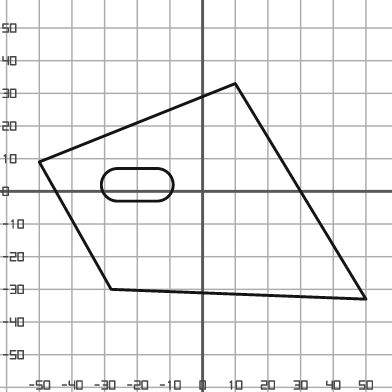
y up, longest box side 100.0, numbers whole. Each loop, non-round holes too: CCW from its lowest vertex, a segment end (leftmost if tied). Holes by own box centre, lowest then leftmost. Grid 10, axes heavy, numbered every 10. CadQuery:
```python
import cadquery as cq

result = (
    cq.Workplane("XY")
    .moveTo(50.0, -33.0)
    .lineTo(10.0, 33.0)
    .lineTo(-50.0, 9.0)
    .lineTo(-28.0, -30.0)
    .close()
    .moveTo(-26.0, -3.0)
    .lineTo(-14.0, -3.0)
    .threePointArc((-9.0, 2.0), (-14.0, 7.0))
    .lineTo(-26.0, 7.0)
    .threePointArc((-31.0, 2.0), (-26.0, -3.0))
    .close()
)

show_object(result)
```